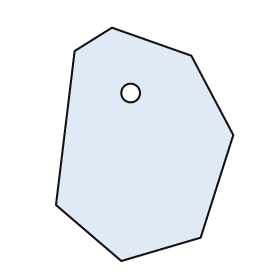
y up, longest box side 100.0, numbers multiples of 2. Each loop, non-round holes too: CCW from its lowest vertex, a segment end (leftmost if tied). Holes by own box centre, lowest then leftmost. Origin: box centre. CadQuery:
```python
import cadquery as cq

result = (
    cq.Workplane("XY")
    .moveTo(-10.0, -50.0)
    .lineTo(24.0, -40.0)
    .lineTo(38.0, 4.0)
    .lineTo(20.0, 38.0)
    .lineTo(-14.0, 50.0)
    .lineTo(-30.0, 40.0)
    .lineTo(-38.0, -26.0)
    .close()
    .moveTo(-6.0, 22.0)
    .circle(4.0)
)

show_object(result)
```